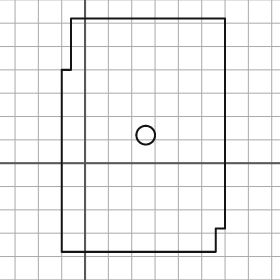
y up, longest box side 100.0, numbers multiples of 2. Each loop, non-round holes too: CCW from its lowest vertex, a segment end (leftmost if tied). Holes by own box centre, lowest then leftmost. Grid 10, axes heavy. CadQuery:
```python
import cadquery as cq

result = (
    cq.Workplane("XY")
    .moveTo(-10.0, -38.0)
    .lineTo(56.0, -38.0)
    .lineTo(56.0, -28.0)
    .lineTo(60.0, -28.0)
    .lineTo(60.0, 62.0)
    .lineTo(-6.0, 62.0)
    .lineTo(-6.0, 40.0)
    .lineTo(-10.0, 40.0)
    .close()
    .moveTo(26.0, 12.0)
    .circle(4.0)
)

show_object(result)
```